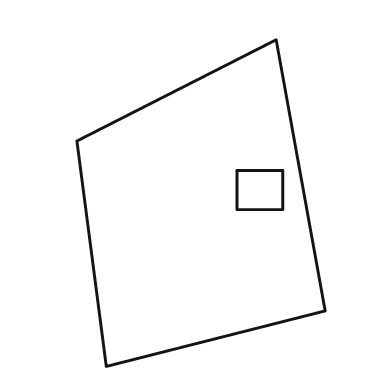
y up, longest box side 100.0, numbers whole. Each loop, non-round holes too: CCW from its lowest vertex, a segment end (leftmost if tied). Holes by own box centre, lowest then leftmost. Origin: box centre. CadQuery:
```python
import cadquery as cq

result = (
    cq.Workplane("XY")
    .moveTo(-29.0, -50.0)
    .lineTo(38.0, -33.0)
    .lineTo(23.0, 50.0)
    .lineTo(-38.0, 19.0)
    .close()
    .moveTo(11.0, -2.0)
    .lineTo(25.0, -2.0)
    .lineTo(25.0, 10.0)
    .lineTo(11.0, 10.0)
    .close()
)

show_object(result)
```